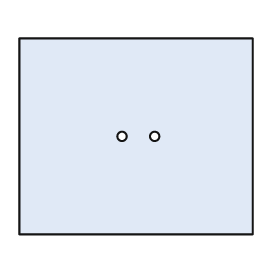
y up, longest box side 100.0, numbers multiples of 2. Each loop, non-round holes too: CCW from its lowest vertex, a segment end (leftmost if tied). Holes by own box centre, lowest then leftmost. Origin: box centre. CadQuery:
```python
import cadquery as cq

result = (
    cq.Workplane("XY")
    .moveTo(-50.0, -42.0)
    .lineTo(50.0, -42.0)
    .lineTo(50.0, 42.0)
    .lineTo(-50.0, 42.0)
    .close()
    .moveTo(-6.0, 0.0)
    .circle(2.0)
    .moveTo(8.0, 0.0)
    .circle(2.0)
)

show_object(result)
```